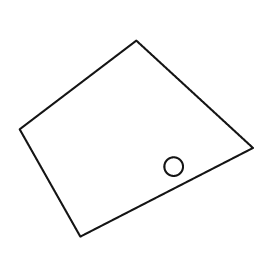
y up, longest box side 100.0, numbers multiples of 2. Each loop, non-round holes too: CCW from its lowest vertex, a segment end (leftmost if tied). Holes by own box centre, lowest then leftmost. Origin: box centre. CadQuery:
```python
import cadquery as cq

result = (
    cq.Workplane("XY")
    .moveTo(-24.0, -42.0)
    .lineTo(50.0, -4.0)
    .lineTo(0.0, 42.0)
    .lineTo(-50.0, 4.0)
    .close()
    .moveTo(16.0, -12.0)
    .circle(4.0)
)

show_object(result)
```